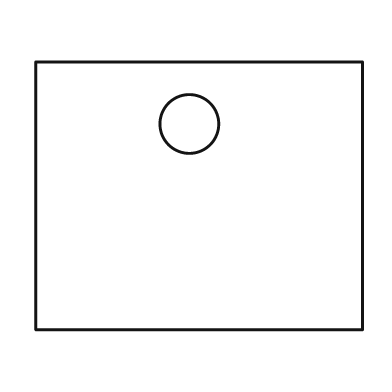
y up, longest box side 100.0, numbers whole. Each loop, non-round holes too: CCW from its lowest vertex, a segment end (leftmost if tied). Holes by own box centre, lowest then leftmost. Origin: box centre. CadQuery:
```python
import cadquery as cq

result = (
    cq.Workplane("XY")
    .moveTo(-50.0, -41.0)
    .lineTo(50.0, -41.0)
    .lineTo(50.0, 41.0)
    .lineTo(-50.0, 41.0)
    .close()
    .moveTo(-3.0, 22.0)
    .circle(9.0)
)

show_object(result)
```